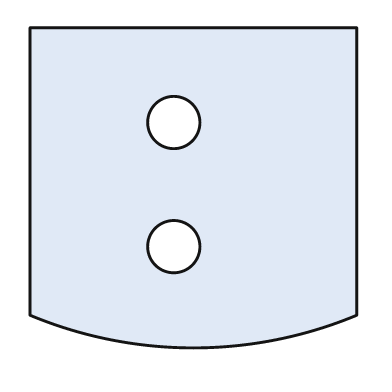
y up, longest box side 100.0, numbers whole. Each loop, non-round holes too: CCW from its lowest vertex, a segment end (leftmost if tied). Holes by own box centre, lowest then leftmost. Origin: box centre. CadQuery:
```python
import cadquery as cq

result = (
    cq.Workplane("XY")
    .moveTo(-50.0, -39.0)
    .threePointArc((0.0, -49.0), (50.0, -39.0))
    .lineTo(50.0, 49.0)
    .lineTo(-50.0, 49.0)
    .close()
    .moveTo(-6.0, -18.0)
    .circle(8.0)
    .moveTo(-6.0, 20.0)
    .circle(8.0)
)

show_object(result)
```